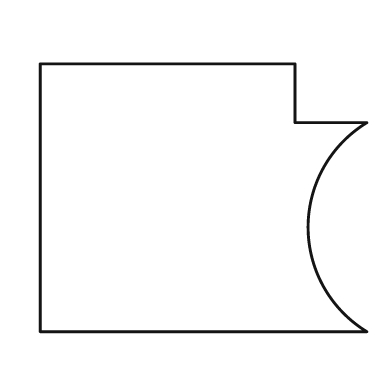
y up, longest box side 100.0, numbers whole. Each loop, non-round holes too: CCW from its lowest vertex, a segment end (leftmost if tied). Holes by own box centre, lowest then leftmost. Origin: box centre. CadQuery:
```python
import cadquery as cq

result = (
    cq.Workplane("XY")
    .moveTo(-50.0, -41.0)
    .lineTo(50.0, -41.0)
    .threePointArc((32.0, -9.0), (50.0, 23.0))
    .lineTo(28.0, 23.0)
    .lineTo(28.0, 41.0)
    .lineTo(-50.0, 41.0)
    .close()
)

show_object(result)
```